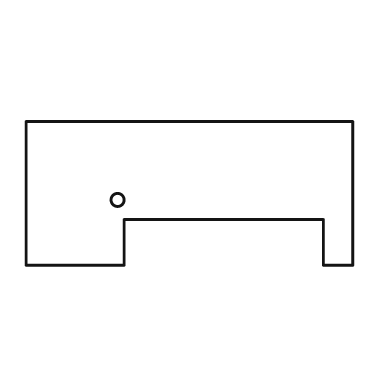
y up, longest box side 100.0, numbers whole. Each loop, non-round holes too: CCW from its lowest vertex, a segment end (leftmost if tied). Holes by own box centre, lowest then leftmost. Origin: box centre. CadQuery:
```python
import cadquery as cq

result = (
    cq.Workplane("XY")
    .moveTo(-50.0, -22.0)
    .lineTo(-20.0, -22.0)
    .lineTo(-20.0, -8.0)
    .lineTo(41.0, -8.0)
    .lineTo(41.0, -22.0)
    .lineTo(50.0, -22.0)
    .lineTo(50.0, 22.0)
    .lineTo(-50.0, 22.0)
    .close()
    .moveTo(-22.0, -2.0)
    .circle(2.0)
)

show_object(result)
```